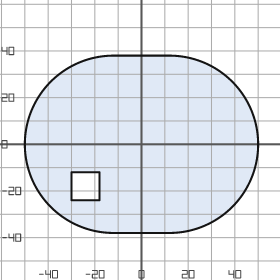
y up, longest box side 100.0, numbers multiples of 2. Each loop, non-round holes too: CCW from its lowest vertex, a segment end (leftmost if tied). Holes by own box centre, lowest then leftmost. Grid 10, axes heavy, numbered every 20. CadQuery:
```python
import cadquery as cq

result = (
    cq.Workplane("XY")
    .moveTo(-12.0, -38.0)
    .lineTo(12.0, -38.0)
    .threePointArc((50.0, 0.0), (12.0, 38.0))
    .lineTo(-12.0, 38.0)
    .threePointArc((-50.0, 0.0), (-12.0, -38.0))
    .close()
    .moveTo(-30.0, -24.0)
    .lineTo(-18.0, -24.0)
    .lineTo(-18.0, -12.0)
    .lineTo(-30.0, -12.0)
    .close()
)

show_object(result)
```